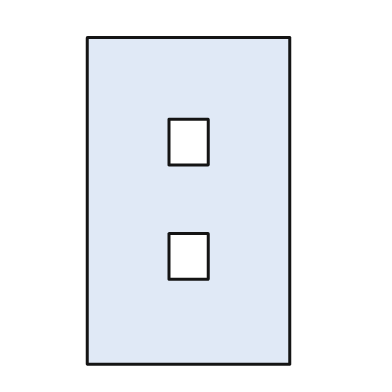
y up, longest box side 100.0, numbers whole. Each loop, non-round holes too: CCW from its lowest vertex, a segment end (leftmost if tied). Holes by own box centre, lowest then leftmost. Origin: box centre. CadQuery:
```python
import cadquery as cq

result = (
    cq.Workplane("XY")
    .moveTo(-31.0, -50.0)
    .lineTo(31.0, -50.0)
    .lineTo(31.0, 50.0)
    .lineTo(-31.0, 50.0)
    .close()
    .moveTo(-6.0, -24.0)
    .lineTo(6.0, -24.0)
    .lineTo(6.0, -10.0)
    .lineTo(-6.0, -10.0)
    .close()
    .moveTo(-6.0, 11.0)
    .lineTo(6.0, 11.0)
    .lineTo(6.0, 25.0)
    .lineTo(-6.0, 25.0)
    .close()
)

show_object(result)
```